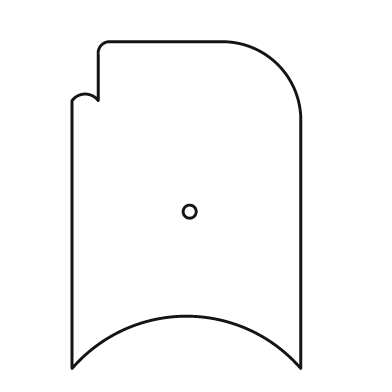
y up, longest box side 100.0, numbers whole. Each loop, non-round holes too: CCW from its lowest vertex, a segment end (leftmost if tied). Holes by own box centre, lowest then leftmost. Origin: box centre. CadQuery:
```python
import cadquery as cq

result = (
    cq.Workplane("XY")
    .moveTo(-35.0, -50.0)
    .threePointArc((0.0, -34.0), (35.0, -50.0))
    .lineTo(35.0, 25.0)
    .threePointArc((28.0, 43.0), (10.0, 50.0))
    .lineTo(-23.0, 50.0)
    .threePointArc((-26.0, 49.0), (-27.0, 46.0))
    .lineTo(-27.0, 32.0)
    .threePointArc((-31.0, 34.0), (-35.0, 32.0))
    .close()
    .moveTo(1.0, -2.0)
    .circle(2.0)
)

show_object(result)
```